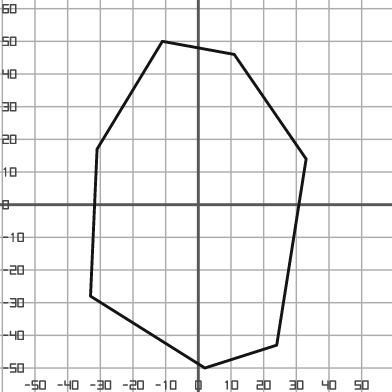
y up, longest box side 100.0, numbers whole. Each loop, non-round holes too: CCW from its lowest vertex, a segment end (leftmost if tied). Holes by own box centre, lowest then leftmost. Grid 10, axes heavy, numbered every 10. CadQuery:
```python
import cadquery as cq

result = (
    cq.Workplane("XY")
    .moveTo(2.0, -50.0)
    .lineTo(24.0, -43.0)
    .lineTo(33.0, 14.0)
    .lineTo(11.0, 46.0)
    .lineTo(-11.0, 50.0)
    .lineTo(-31.0, 17.0)
    .lineTo(-33.0, -28.0)
    .close()
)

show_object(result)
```